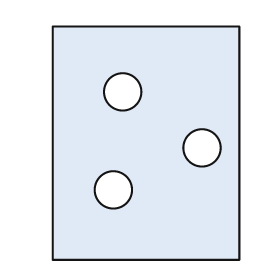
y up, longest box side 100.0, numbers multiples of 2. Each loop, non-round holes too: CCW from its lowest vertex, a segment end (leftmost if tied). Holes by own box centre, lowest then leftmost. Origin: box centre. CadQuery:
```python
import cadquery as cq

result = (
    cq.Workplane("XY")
    .moveTo(-40.0, -50.0)
    .lineTo(40.0, -50.0)
    .lineTo(40.0, 50.0)
    .lineTo(-40.0, 50.0)
    .close()
    .moveTo(-14.0, -20.0)
    .circle(8.0)
    .moveTo(24.0, -2.0)
    .circle(8.0)
    .moveTo(-10.0, 22.0)
    .circle(8.0)
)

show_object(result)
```